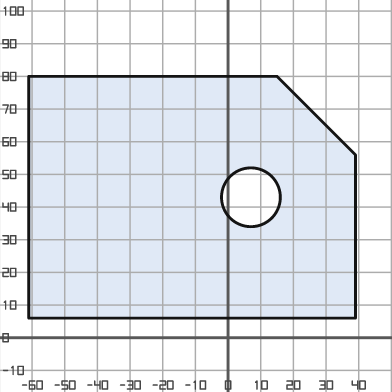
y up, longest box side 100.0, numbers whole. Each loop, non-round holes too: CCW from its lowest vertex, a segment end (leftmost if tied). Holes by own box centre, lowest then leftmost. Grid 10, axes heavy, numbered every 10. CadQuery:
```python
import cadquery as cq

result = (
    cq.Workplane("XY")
    .moveTo(-61.0, 6.0)
    .lineTo(39.0, 6.0)
    .lineTo(39.0, 56.0)
    .lineTo(15.0, 80.0)
    .lineTo(-61.0, 80.0)
    .close()
    .moveTo(7.0, 43.0)
    .circle(9.0)
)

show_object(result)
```